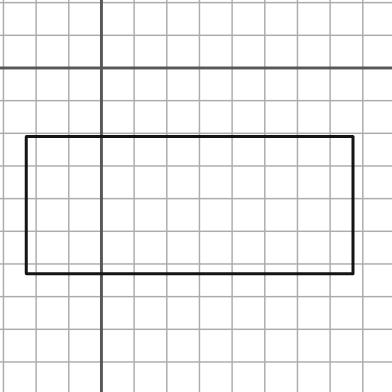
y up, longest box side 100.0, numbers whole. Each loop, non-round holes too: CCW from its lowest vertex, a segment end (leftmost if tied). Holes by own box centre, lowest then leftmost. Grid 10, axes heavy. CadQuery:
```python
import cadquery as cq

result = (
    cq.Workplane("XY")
    .moveTo(-23.0, -63.0)
    .lineTo(77.0, -63.0)
    .lineTo(77.0, -21.0)
    .lineTo(-23.0, -21.0)
    .close()
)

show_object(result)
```